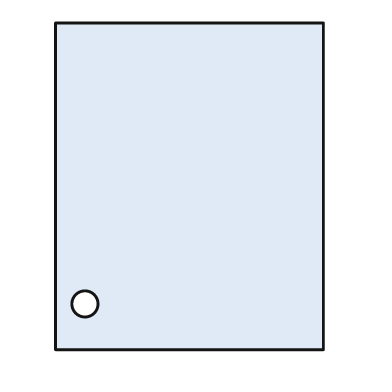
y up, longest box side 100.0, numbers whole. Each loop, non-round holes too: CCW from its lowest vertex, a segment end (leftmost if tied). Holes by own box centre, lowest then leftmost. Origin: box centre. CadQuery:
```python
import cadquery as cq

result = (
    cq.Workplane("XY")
    .moveTo(-41.0, -50.0)
    .lineTo(41.0, -50.0)
    .lineTo(41.0, 50.0)
    .lineTo(-41.0, 50.0)
    .close()
    .moveTo(-32.0, -36.0)
    .circle(4.0)
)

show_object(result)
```